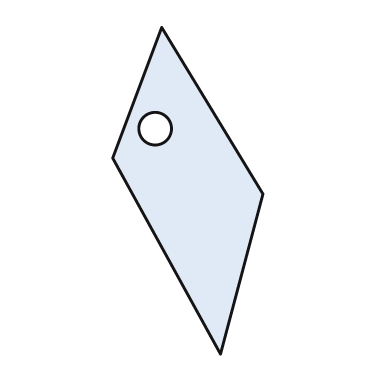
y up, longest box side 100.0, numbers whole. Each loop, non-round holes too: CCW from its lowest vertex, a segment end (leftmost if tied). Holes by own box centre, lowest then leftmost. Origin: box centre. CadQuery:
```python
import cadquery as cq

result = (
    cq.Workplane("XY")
    .moveTo(10.0, -50.0)
    .lineTo(23.0, -1.0)
    .lineTo(-8.0, 50.0)
    .lineTo(-23.0, 10.0)
    .close()
    .moveTo(-10.0, 19.0)
    .circle(5.0)
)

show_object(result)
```